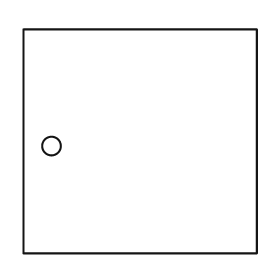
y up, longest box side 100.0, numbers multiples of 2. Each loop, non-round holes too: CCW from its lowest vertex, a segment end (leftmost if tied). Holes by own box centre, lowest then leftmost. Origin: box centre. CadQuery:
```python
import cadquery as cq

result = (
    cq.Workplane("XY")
    .moveTo(-50.0, -48.0)
    .lineTo(50.0, -48.0)
    .lineTo(50.0, 48.0)
    .lineTo(-50.0, 48.0)
    .close()
    .moveTo(-38.0, -2.0)
    .circle(4.0)
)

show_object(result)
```